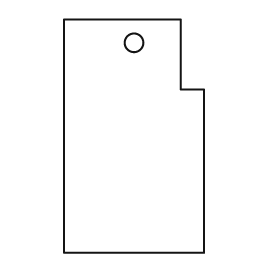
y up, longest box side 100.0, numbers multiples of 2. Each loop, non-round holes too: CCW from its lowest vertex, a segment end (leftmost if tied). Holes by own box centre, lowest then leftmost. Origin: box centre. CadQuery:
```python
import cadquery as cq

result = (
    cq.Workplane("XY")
    .moveTo(-30.0, -50.0)
    .lineTo(30.0, -50.0)
    .lineTo(30.0, 20.0)
    .lineTo(20.0, 20.0)
    .lineTo(20.0, 50.0)
    .lineTo(-30.0, 50.0)
    .close()
    .moveTo(0.0, 40.0)
    .circle(4.0)
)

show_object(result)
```